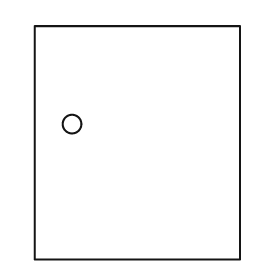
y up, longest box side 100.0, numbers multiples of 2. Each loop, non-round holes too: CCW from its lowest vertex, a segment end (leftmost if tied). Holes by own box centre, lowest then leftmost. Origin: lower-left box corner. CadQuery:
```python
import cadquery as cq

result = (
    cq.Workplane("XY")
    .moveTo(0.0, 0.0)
    .lineTo(88.0, 0.0)
    .lineTo(88.0, 100.0)
    .lineTo(0.0, 100.0)
    .close()
    .moveTo(16.0, 58.0)
    .circle(4.0)
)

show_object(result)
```